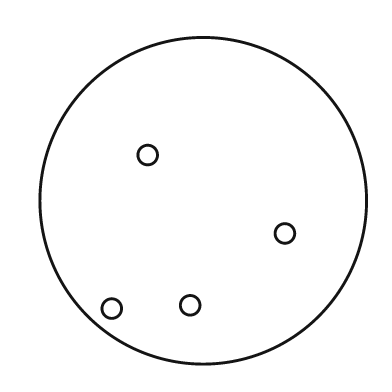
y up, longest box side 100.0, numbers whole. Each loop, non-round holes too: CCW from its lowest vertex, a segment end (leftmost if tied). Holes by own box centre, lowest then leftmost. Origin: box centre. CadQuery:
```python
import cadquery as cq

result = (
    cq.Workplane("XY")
    .moveTo(0.0, 0.0)
    .circle(50.0)
    .moveTo(-28.0, -33.0)
    .circle(3.0)
    .moveTo(-4.0, -32.0)
    .circle(3.0)
    .moveTo(25.0, -10.0)
    .circle(3.0)
    .moveTo(-17.0, 14.0)
    .circle(3.0)
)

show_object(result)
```